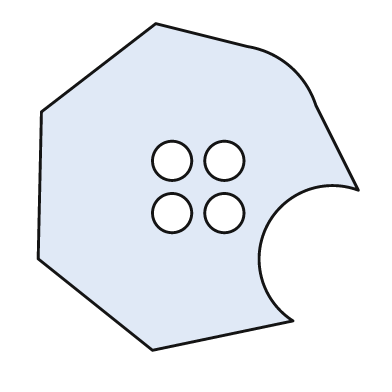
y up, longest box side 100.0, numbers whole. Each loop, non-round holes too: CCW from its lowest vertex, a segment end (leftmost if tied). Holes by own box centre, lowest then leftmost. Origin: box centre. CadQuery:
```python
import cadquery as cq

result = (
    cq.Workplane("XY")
    .moveTo(-14.0, -50.0)
    .lineTo(29.0, -41.0)
    .threePointArc((21.0, -12.0), (49.0, -1.0))
    .lineTo(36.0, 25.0)
    .threePointArc((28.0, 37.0), (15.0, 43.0))
    .lineTo(-13.0, 50.0)
    .lineTo(-48.0, 23.0)
    .lineTo(-49.0, -22.0)
    .close()
    .moveTo(-8.0, -8.0)
    .circle(6.0)
    .moveTo(8.0, -8.0)
    .circle(6.0)
    .moveTo(-8.0, 8.0)
    .circle(6.0)
    .moveTo(8.0, 8.0)
    .circle(6.0)
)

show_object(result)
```